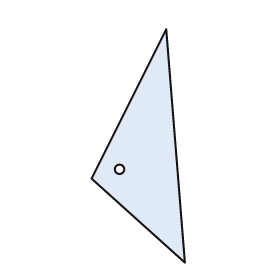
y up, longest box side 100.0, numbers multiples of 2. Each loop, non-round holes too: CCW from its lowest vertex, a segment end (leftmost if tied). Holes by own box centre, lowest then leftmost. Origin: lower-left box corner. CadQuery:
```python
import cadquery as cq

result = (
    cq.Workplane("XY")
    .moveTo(40.0, 0.0)
    .lineTo(32.0, 100.0)
    .lineTo(0.0, 36.0)
    .close()
    .moveTo(12.0, 40.0)
    .circle(2.0)
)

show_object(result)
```